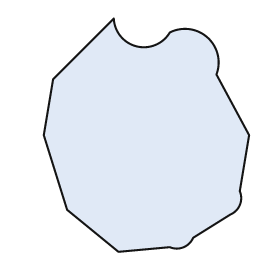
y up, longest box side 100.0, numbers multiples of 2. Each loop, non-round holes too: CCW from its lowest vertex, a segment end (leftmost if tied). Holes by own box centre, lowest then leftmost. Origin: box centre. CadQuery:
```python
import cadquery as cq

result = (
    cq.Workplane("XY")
    .moveTo(-12.0, -50.0)
    .lineTo(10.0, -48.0)
    .threePointArc((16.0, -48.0), (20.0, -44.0))
    .lineTo(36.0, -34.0)
    .threePointArc((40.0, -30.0), (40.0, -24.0))
    .lineTo(44.0, 0.0)
    .lineTo(30.0, 26.0)
    .threePointArc((26.0, 42.0), (10.0, 44.0))
    .threePointArc((-4.0, 38.0), (-14.0, 50.0))
    .lineTo(-40.0, 24.0)
    .lineTo(-44.0, 0.0)
    .lineTo(-34.0, -32.0)
    .close()
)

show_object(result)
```